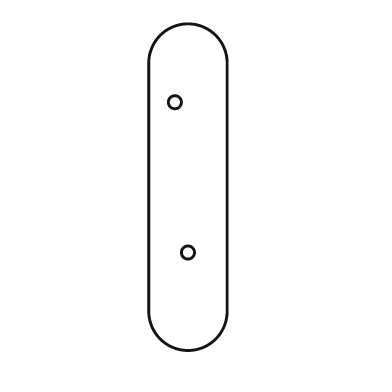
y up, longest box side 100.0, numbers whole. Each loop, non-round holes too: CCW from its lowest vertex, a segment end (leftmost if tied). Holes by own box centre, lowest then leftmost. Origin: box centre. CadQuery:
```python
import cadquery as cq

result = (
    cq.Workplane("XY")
    .moveTo(-12.0, -38.0)
    .threePointArc((0.0, -50.0), (12.0, -38.0))
    .lineTo(12.0, 38.0)
    .threePointArc((0.0, 50.0), (-12.0, 38.0))
    .close()
    .moveTo(0.0, -20.0)
    .circle(2.0)
    .moveTo(-4.0, 26.0)
    .circle(2.0)
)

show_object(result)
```